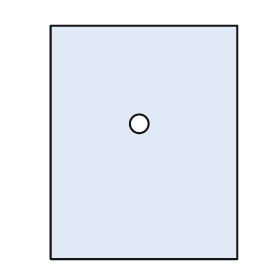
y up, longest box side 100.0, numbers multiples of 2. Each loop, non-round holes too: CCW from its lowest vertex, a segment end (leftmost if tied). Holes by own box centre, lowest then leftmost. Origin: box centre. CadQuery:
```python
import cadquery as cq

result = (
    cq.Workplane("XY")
    .moveTo(-40.0, -50.0)
    .lineTo(40.0, -50.0)
    .lineTo(40.0, 50.0)
    .lineTo(-40.0, 50.0)
    .close()
    .moveTo(-2.0, 8.0)
    .circle(4.0)
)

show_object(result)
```